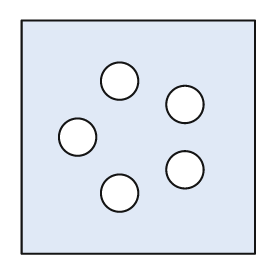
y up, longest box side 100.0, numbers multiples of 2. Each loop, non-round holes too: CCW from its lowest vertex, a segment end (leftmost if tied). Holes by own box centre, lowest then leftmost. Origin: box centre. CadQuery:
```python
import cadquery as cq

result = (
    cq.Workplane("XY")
    .moveTo(-50.0, -50.0)
    .lineTo(50.0, -50.0)
    .lineTo(50.0, 50.0)
    .lineTo(-50.0, 50.0)
    .close()
    .moveTo(-8.0, -24.0)
    .circle(8.0)
    .moveTo(20.0, -14.0)
    .circle(8.0)
    .moveTo(-26.0, 0.0)
    .circle(8.0)
    .moveTo(20.0, 14.0)
    .circle(8.0)
    .moveTo(-8.0, 24.0)
    .circle(8.0)
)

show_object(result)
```